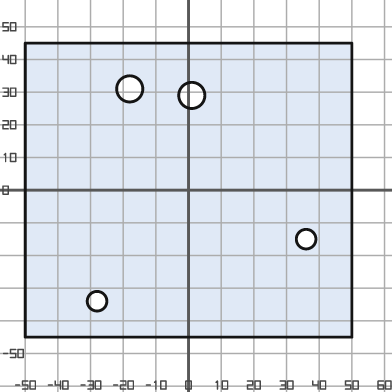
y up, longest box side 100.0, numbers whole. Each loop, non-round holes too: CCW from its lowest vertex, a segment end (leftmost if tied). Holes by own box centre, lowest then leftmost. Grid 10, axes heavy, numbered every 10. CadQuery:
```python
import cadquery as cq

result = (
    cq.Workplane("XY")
    .moveTo(-50.0, -45.0)
    .lineTo(50.0, -45.0)
    .lineTo(50.0, 45.0)
    .lineTo(-50.0, 45.0)
    .close()
    .moveTo(-28.0, -34.0)
    .circle(3.0)
    .moveTo(36.0, -15.0)
    .circle(3.0)
    .moveTo(1.0, 29.0)
    .circle(4.0)
    .moveTo(-18.0, 31.0)
    .circle(4.0)
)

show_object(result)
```